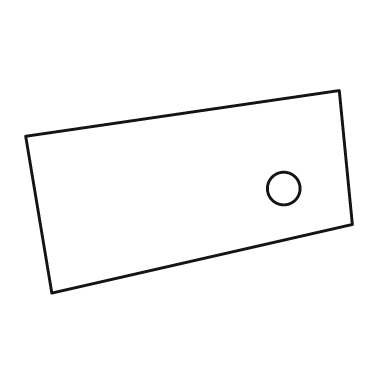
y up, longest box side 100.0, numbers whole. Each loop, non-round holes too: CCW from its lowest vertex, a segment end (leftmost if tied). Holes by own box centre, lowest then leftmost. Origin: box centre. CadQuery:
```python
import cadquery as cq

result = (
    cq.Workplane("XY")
    .moveTo(-42.0, -31.0)
    .lineTo(50.0, -10.0)
    .lineTo(46.0, 31.0)
    .lineTo(-50.0, 17.0)
    .close()
    .moveTo(29.0, 1.0)
    .circle(5.0)
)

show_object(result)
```